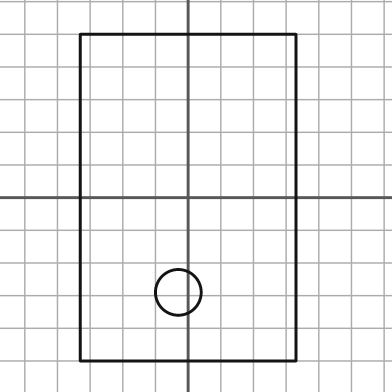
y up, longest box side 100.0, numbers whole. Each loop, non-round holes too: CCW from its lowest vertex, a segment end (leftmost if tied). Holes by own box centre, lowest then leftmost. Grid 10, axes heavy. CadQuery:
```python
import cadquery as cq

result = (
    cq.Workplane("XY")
    .moveTo(-33.0, -50.0)
    .lineTo(33.0, -50.0)
    .lineTo(33.0, 50.0)
    .lineTo(-33.0, 50.0)
    .close()
    .moveTo(-3.0, -29.0)
    .circle(7.0)
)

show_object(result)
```